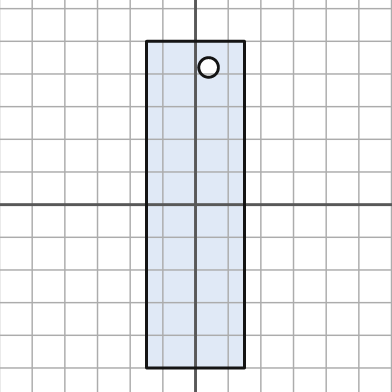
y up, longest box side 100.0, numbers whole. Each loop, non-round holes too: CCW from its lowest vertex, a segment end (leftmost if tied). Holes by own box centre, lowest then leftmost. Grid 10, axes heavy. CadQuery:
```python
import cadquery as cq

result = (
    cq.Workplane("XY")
    .moveTo(-15.0, -50.0)
    .lineTo(15.0, -50.0)
    .lineTo(15.0, 50.0)
    .lineTo(-15.0, 50.0)
    .close()
    .moveTo(4.0, 42.0)
    .circle(3.0)
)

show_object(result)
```